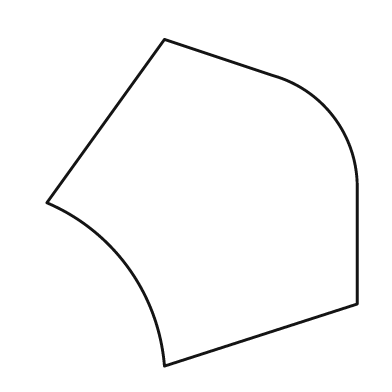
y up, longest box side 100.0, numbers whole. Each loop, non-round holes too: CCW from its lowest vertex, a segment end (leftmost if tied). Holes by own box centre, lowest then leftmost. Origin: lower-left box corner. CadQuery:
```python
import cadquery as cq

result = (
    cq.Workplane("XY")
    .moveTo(36.0, 0.0)
    .lineTo(95.0, 19.0)
    .lineTo(95.0, 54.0)
    .threePointArc((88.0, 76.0), (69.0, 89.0))
    .lineTo(36.0, 100.0)
    .lineTo(0.0, 50.0)
    .threePointArc((25.0, 30.0), (36.0, 0.0))
    .close()
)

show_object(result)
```